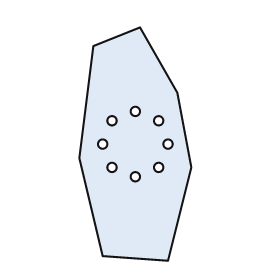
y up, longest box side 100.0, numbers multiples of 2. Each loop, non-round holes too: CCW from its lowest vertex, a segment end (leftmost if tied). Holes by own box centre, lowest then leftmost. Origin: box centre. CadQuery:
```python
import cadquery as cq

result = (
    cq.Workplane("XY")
    .moveTo(14.0, -50.0)
    .lineTo(24.0, -10.0)
    .lineTo(18.0, 22.0)
    .lineTo(2.0, 50.0)
    .lineTo(-18.0, 42.0)
    .lineTo(-24.0, -6.0)
    .lineTo(-14.0, -48.0)
    .close()
    .moveTo(0.0, -14.0)
    .circle(2.0)
    .moveTo(-10.0, -10.0)
    .circle(2.0)
    .moveTo(10.0, -10.0)
    .circle(2.0)
    .moveTo(-14.0, 0.0)
    .circle(2.0)
    .moveTo(14.0, 0.0)
    .circle(2.0)
    .moveTo(-10.0, 10.0)
    .circle(2.0)
    .moveTo(10.0, 10.0)
    .circle(2.0)
    .moveTo(0.0, 14.0)
    .circle(2.0)
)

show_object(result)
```